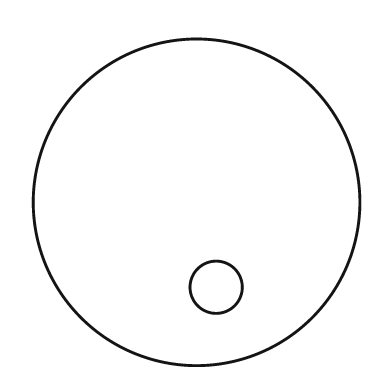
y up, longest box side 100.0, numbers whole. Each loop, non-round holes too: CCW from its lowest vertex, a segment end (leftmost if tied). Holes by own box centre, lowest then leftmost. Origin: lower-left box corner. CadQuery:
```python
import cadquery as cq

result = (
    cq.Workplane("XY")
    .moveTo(50.0, 50.0)
    .circle(50.0)
    .moveTo(56.0, 24.0)
    .circle(8.0)
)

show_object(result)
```